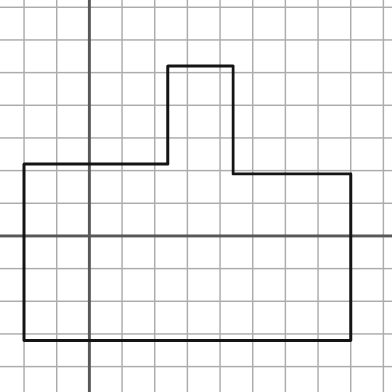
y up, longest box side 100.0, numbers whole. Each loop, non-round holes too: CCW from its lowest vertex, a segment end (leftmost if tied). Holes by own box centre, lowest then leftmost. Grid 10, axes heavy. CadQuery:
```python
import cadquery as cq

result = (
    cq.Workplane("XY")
    .moveTo(-20.0, -32.0)
    .lineTo(80.0, -32.0)
    .lineTo(80.0, 19.0)
    .lineTo(44.0, 19.0)
    .lineTo(44.0, 52.0)
    .lineTo(24.0, 52.0)
    .lineTo(24.0, 22.0)
    .lineTo(-20.0, 22.0)
    .close()
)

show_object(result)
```